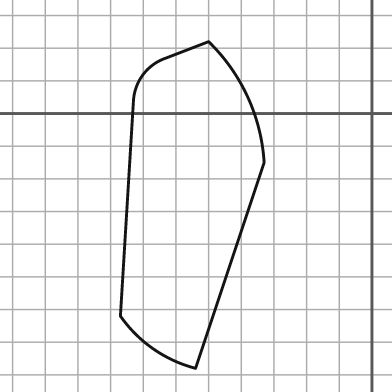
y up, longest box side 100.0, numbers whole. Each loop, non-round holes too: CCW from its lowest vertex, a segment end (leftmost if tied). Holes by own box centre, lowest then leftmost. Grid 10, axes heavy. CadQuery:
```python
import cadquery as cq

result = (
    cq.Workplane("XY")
    .moveTo(-54.0, -78.0)
    .lineTo(-33.0, -15.0)
    .threePointArc((-38.0, 5.0), (-50.0, 22.0))
    .lineTo(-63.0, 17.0)
    .threePointArc((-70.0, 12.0), (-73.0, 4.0))
    .lineTo(-77.0, -62.0)
    .threePointArc((-67.0, -72.0), (-54.0, -78.0))
    .close()
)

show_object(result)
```